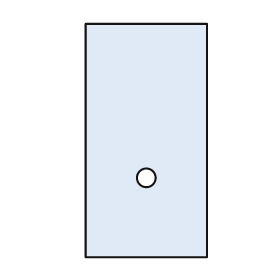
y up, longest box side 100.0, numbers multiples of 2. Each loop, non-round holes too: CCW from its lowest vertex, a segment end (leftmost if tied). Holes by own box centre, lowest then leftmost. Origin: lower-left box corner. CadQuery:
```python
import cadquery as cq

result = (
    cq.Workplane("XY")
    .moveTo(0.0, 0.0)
    .lineTo(52.0, 0.0)
    .lineTo(52.0, 100.0)
    .lineTo(0.0, 100.0)
    .close()
    .moveTo(26.0, 34.0)
    .circle(4.0)
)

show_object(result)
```